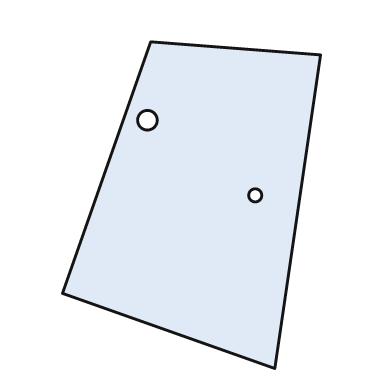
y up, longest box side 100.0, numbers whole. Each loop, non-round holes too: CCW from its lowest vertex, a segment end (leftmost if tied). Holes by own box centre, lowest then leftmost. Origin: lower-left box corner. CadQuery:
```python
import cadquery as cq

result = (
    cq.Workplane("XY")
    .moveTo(65.0, 0.0)
    .lineTo(79.0, 96.0)
    .lineTo(27.0, 100.0)
    .lineTo(0.0, 23.0)
    .close()
    .moveTo(59.0, 53.0)
    .circle(2.0)
    .moveTo(26.0, 76.0)
    .circle(3.0)
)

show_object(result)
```